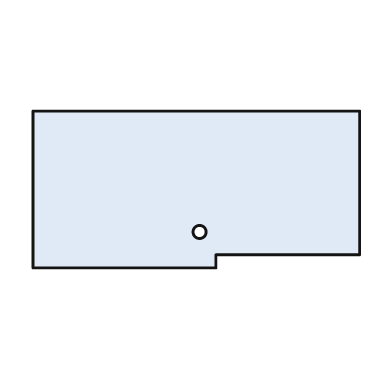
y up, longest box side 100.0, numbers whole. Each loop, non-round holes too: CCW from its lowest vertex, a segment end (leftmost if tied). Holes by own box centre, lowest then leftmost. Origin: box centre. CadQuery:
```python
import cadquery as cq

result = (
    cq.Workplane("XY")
    .moveTo(-50.0, -24.0)
    .lineTo(6.0, -24.0)
    .lineTo(6.0, -20.0)
    .lineTo(50.0, -20.0)
    .lineTo(50.0, 24.0)
    .lineTo(-50.0, 24.0)
    .close()
    .moveTo(1.0, -13.0)
    .circle(2.0)
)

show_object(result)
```